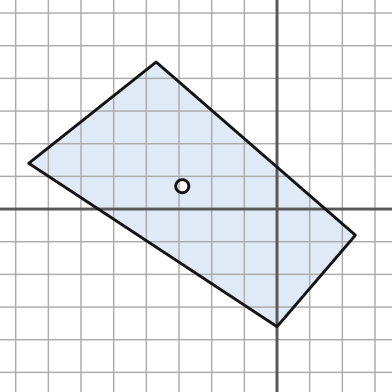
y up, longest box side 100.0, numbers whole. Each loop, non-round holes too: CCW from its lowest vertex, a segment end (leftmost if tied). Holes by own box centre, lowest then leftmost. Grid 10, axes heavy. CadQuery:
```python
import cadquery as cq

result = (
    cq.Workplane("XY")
    .moveTo(0.0, -36.0)
    .lineTo(24.0, -8.0)
    .lineTo(-37.0, 45.0)
    .lineTo(-76.0, 14.0)
    .close()
    .moveTo(-29.0, 7.0)
    .circle(2.0)
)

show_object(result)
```